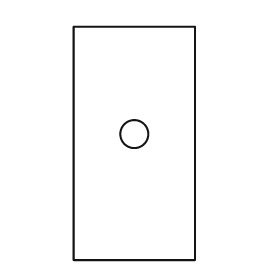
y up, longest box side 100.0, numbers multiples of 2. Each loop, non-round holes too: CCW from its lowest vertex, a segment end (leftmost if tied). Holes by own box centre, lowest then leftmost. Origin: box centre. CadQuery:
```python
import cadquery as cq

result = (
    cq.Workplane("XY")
    .moveTo(-26.0, -50.0)
    .lineTo(26.0, -50.0)
    .lineTo(26.0, 50.0)
    .lineTo(-26.0, 50.0)
    .close()
    .moveTo(0.0, 4.0)
    .circle(6.0)
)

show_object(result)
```